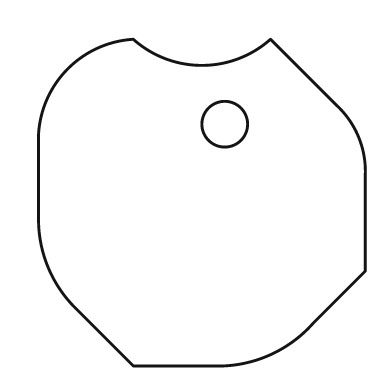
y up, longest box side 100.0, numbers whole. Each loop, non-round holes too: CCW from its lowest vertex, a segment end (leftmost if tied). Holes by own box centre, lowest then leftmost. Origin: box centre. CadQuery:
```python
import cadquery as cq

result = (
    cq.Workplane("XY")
    .moveTo(-21.0, -50.0)
    .lineTo(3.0, -50.0)
    .threePointArc((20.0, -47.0), (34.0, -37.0))
    .lineTo(50.0, -21.0)
    .lineTo(50.0, 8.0)
    .threePointArc((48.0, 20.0), (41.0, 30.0))
    .lineTo(21.0, 50.0)
    .threePointArc((0.0, 42.0), (-21.0, 50.0))
    .threePointArc((-41.0, 41.0), (-50.0, 21.0))
    .lineTo(-50.0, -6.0)
    .threePointArc((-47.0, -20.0), (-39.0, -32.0))
    .close()
    .moveTo(7.0, 24.0)
    .circle(7.0)
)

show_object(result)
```